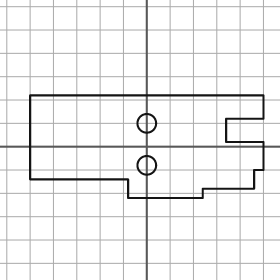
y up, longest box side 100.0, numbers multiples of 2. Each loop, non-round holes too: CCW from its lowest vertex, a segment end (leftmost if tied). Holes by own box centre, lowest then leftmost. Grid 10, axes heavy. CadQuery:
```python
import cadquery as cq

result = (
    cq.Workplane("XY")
    .moveTo(-8.0, -22.0)
    .lineTo(24.0, -22.0)
    .lineTo(24.0, -18.0)
    .lineTo(46.0, -18.0)
    .lineTo(46.0, -10.0)
    .lineTo(50.0, -10.0)
    .lineTo(50.0, 2.0)
    .lineTo(34.0, 2.0)
    .lineTo(34.0, 12.0)
    .lineTo(50.0, 12.0)
    .lineTo(50.0, 22.0)
    .lineTo(-50.0, 22.0)
    .lineTo(-50.0, -14.0)
    .lineTo(-8.0, -14.0)
    .close()
    .moveTo(0.0, -8.0)
    .circle(4.0)
    .moveTo(0.0, 10.0)
    .circle(4.0)
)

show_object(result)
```